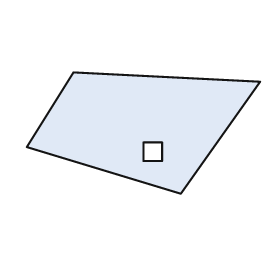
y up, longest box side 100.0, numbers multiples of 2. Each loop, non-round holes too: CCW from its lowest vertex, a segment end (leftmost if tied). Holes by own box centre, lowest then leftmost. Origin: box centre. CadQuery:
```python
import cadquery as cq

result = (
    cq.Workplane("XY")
    .moveTo(16.0, -26.0)
    .lineTo(50.0, 22.0)
    .lineTo(-30.0, 26.0)
    .lineTo(-50.0, -6.0)
    .close()
    .moveTo(0.0, -12.0)
    .lineTo(8.0, -12.0)
    .lineTo(8.0, -4.0)
    .lineTo(0.0, -4.0)
    .close()
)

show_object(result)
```